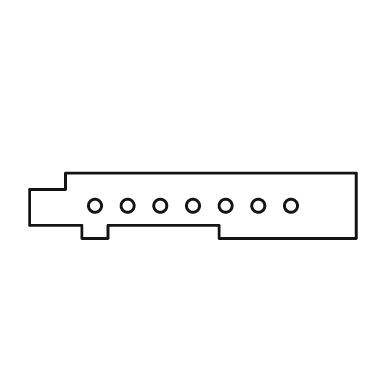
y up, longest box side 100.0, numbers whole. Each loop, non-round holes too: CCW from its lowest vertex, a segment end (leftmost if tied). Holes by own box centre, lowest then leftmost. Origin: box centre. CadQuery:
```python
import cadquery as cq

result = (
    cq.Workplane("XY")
    .moveTo(-34.0, -10.0)
    .lineTo(-26.0, -10.0)
    .lineTo(-26.0, -6.0)
    .lineTo(8.0, -6.0)
    .lineTo(8.0, -10.0)
    .lineTo(50.0, -10.0)
    .lineTo(50.0, 10.0)
    .lineTo(-39.0, 10.0)
    .lineTo(-39.0, 5.0)
    .lineTo(-50.0, 5.0)
    .lineTo(-50.0, -6.0)
    .lineTo(-34.0, -6.0)
    .close()
    .moveTo(-30.0, 0.0)
    .circle(2.0)
    .moveTo(-20.0, 0.0)
    .circle(2.0)
    .moveTo(-10.0, 0.0)
    .circle(2.0)
    .moveTo(0.0, 0.0)
    .circle(2.0)
    .moveTo(10.0, 0.0)
    .circle(2.0)
    .moveTo(20.0, 0.0)
    .circle(2.0)
    .moveTo(30.0, 0.0)
    .circle(2.0)
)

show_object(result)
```